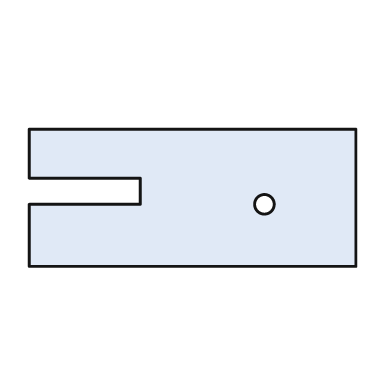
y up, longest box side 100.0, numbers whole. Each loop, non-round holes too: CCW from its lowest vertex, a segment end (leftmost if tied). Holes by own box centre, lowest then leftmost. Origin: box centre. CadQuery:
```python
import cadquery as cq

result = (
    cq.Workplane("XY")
    .moveTo(-50.0, -21.0)
    .lineTo(50.0, -21.0)
    .lineTo(50.0, 21.0)
    .lineTo(-50.0, 21.0)
    .lineTo(-50.0, 6.0)
    .lineTo(-16.0, 6.0)
    .lineTo(-16.0, -2.0)
    .lineTo(-50.0, -2.0)
    .close()
    .moveTo(22.0, -2.0)
    .circle(3.0)
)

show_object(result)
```